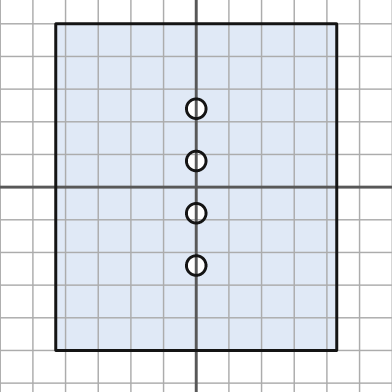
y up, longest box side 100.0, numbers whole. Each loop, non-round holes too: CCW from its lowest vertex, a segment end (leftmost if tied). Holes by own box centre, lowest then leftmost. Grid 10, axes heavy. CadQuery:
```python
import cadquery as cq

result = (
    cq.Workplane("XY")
    .moveTo(-43.0, -50.0)
    .lineTo(43.0, -50.0)
    .lineTo(43.0, 50.0)
    .lineTo(-43.0, 50.0)
    .close()
    .moveTo(0.0, -24.0)
    .circle(3.0)
    .moveTo(0.0, -8.0)
    .circle(3.0)
    .moveTo(0.0, 8.0)
    .circle(3.0)
    .moveTo(0.0, 24.0)
    .circle(3.0)
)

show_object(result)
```